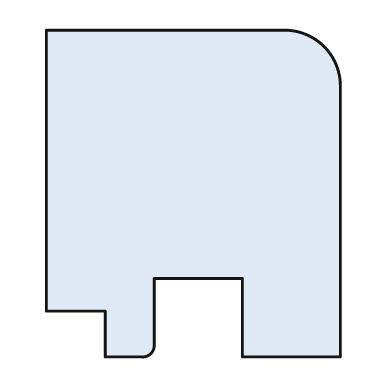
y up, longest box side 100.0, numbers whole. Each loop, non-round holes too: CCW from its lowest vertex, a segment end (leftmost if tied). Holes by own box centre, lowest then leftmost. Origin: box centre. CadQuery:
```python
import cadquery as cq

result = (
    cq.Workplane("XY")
    .moveTo(-27.0, -50.0)
    .lineTo(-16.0, -50.0)
    .threePointArc((-13.0, -49.0), (-12.0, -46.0))
    .lineTo(-12.0, -26.0)
    .lineTo(15.0, -26.0)
    .lineTo(15.0, -50.0)
    .lineTo(45.0, -50.0)
    .lineTo(45.0, 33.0)
    .threePointArc((40.0, 45.0), (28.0, 50.0))
    .lineTo(-45.0, 50.0)
    .lineTo(-45.0, -36.0)
    .lineTo(-27.0, -36.0)
    .close()
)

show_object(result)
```